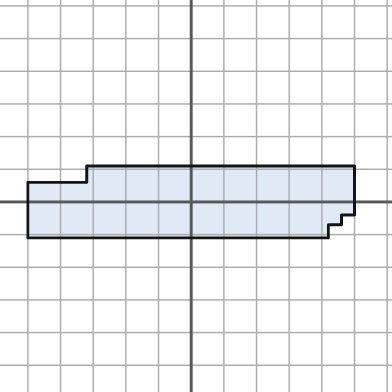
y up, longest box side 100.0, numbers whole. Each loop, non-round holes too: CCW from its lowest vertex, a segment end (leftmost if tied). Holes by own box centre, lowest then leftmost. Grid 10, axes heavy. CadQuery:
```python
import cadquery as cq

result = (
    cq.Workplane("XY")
    .moveTo(-50.0, -11.0)
    .lineTo(42.0, -11.0)
    .lineTo(42.0, -7.0)
    .lineTo(46.0, -7.0)
    .lineTo(46.0, -4.0)
    .lineTo(50.0, -4.0)
    .lineTo(50.0, 11.0)
    .lineTo(-32.0, 11.0)
    .lineTo(-32.0, 6.0)
    .lineTo(-50.0, 6.0)
    .close()
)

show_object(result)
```